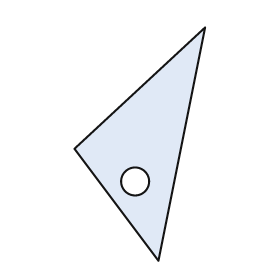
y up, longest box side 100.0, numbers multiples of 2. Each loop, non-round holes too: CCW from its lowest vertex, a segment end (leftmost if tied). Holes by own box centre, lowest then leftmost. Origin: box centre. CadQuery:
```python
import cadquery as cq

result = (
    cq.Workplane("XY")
    .moveTo(8.0, -50.0)
    .lineTo(28.0, 50.0)
    .lineTo(-28.0, -2.0)
    .close()
    .moveTo(-2.0, -16.0)
    .circle(6.0)
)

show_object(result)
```